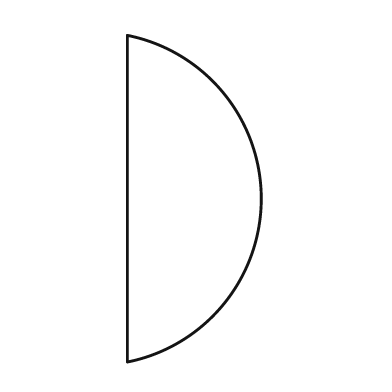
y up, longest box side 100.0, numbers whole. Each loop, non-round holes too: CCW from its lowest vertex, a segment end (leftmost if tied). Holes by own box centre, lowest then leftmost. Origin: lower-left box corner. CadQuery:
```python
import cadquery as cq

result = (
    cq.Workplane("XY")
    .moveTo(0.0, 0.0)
    .threePointArc((41.0, 50.0), (0.0, 100.0))
    .close()
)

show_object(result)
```